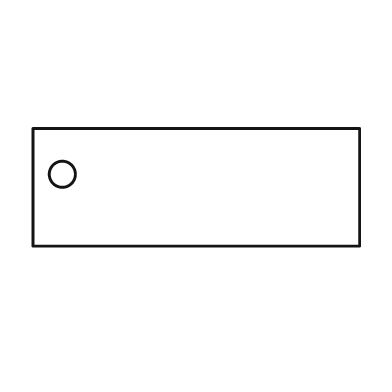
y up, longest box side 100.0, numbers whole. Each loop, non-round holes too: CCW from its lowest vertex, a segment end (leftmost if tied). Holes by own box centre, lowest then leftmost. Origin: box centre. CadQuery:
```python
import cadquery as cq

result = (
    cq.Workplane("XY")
    .moveTo(-50.0, -18.0)
    .lineTo(50.0, -18.0)
    .lineTo(50.0, 18.0)
    .lineTo(-50.0, 18.0)
    .close()
    .moveTo(-41.0, 4.0)
    .circle(4.0)
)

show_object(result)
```